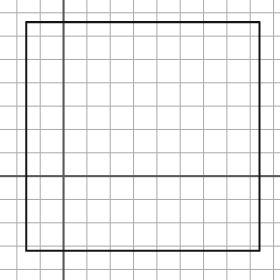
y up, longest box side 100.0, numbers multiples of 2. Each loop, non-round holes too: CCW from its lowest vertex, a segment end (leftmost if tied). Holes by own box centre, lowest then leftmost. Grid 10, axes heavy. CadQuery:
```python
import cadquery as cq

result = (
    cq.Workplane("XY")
    .moveTo(-16.0, -32.0)
    .lineTo(84.0, -32.0)
    .lineTo(84.0, 66.0)
    .lineTo(-16.0, 66.0)
    .close()
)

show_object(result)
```